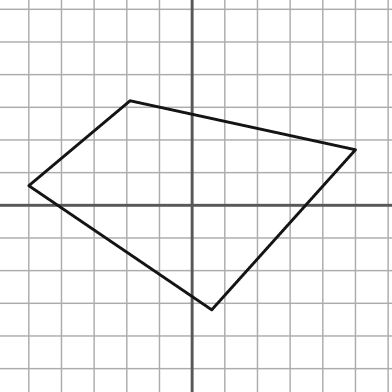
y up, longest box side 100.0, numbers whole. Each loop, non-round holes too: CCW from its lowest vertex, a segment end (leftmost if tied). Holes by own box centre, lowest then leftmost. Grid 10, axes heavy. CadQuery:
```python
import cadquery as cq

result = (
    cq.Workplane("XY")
    .moveTo(6.0, -32.0)
    .lineTo(50.0, 17.0)
    .lineTo(-19.0, 32.0)
    .lineTo(-50.0, 6.0)
    .close()
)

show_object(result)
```